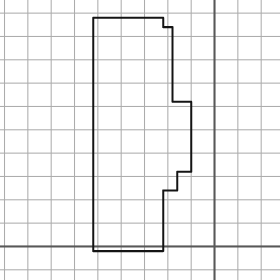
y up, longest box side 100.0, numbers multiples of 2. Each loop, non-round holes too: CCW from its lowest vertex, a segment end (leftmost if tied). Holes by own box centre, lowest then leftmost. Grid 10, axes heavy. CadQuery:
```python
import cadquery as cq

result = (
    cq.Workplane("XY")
    .moveTo(-52.0, -2.0)
    .lineTo(-22.0, -2.0)
    .lineTo(-22.0, 24.0)
    .lineTo(-16.0, 24.0)
    .lineTo(-16.0, 32.0)
    .lineTo(-10.0, 32.0)
    .lineTo(-10.0, 62.0)
    .lineTo(-18.0, 62.0)
    .lineTo(-18.0, 94.0)
    .lineTo(-22.0, 94.0)
    .lineTo(-22.0, 98.0)
    .lineTo(-52.0, 98.0)
    .close()
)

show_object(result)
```